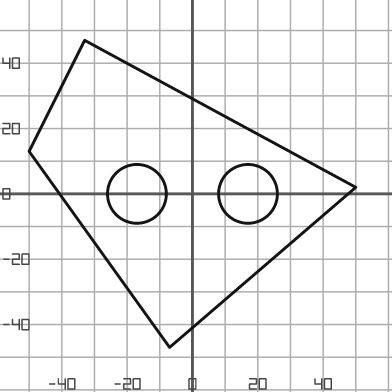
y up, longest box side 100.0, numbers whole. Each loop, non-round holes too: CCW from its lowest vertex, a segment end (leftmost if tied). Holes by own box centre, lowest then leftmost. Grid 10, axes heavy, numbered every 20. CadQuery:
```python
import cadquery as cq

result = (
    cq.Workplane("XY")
    .moveTo(-7.0, -47.0)
    .lineTo(50.0, 2.0)
    .lineTo(-33.0, 47.0)
    .lineTo(-50.0, 13.0)
    .close()
    .moveTo(-17.0, 0.0)
    .circle(9.0)
    .moveTo(17.0, 0.0)
    .circle(9.0)
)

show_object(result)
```